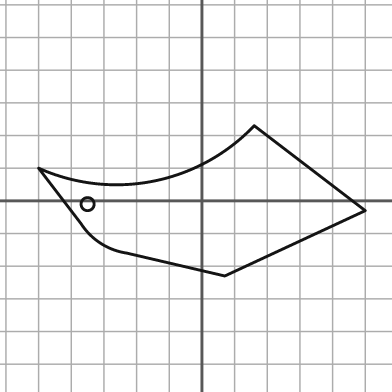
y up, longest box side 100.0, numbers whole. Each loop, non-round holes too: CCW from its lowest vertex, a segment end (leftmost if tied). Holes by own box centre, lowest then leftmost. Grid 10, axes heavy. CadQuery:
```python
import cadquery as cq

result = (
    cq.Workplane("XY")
    .moveTo(7.0, -23.0)
    .lineTo(50.0, -3.0)
    .lineTo(16.0, 23.0)
    .threePointArc((-15.0, 6.0), (-50.0, 10.0))
    .lineTo(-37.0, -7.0)
    .threePointArc((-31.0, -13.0), (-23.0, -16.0))
    .close()
    .moveTo(-35.0, -1.0)
    .circle(2.0)
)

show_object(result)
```